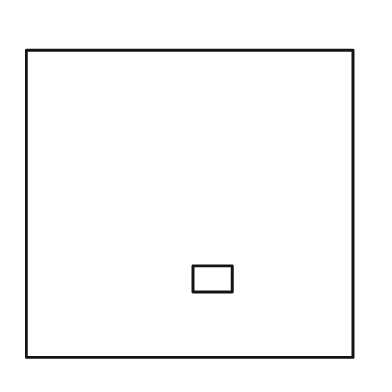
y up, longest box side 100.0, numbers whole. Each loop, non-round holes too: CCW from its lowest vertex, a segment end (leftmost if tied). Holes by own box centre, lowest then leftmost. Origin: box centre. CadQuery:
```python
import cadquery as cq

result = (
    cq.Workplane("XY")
    .moveTo(-50.0, -47.0)
    .lineTo(50.0, -47.0)
    .lineTo(50.0, 47.0)
    .lineTo(-50.0, 47.0)
    .close()
    .moveTo(1.0, -27.0)
    .lineTo(13.0, -27.0)
    .lineTo(13.0, -19.0)
    .lineTo(1.0, -19.0)
    .close()
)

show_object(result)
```